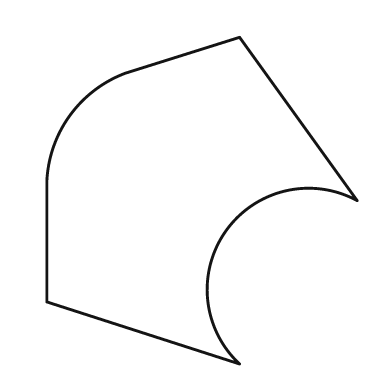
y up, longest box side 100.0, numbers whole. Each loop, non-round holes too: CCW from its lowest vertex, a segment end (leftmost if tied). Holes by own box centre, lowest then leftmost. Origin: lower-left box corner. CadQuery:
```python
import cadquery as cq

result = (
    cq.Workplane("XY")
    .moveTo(59.0, 0.0)
    .threePointArc((55.0, 41.0), (95.0, 50.0))
    .lineTo(59.0, 100.0)
    .lineTo(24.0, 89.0)
    .threePointArc((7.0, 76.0), (0.0, 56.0))
    .lineTo(0.0, 19.0)
    .close()
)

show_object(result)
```